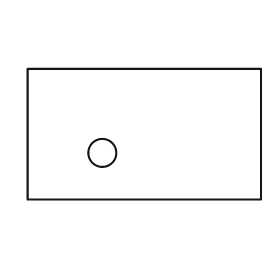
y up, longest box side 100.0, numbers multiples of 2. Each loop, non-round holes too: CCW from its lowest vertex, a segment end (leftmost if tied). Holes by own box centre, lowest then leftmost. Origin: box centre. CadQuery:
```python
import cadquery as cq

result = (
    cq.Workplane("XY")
    .moveTo(-50.0, -28.0)
    .lineTo(50.0, -28.0)
    .lineTo(50.0, 28.0)
    .lineTo(-50.0, 28.0)
    .close()
    .moveTo(-18.0, -8.0)
    .circle(6.0)
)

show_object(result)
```